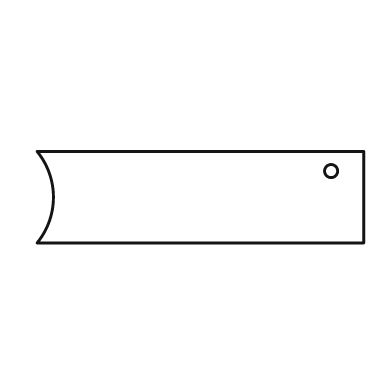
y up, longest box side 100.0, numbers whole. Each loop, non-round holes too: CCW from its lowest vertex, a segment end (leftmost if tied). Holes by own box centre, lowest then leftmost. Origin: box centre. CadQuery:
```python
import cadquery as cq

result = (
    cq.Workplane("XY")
    .moveTo(-50.0, -14.0)
    .lineTo(50.0, -14.0)
    .lineTo(50.0, 14.0)
    .lineTo(-50.0, 14.0)
    .threePointArc((-45.0, 0.0), (-50.0, -14.0))
    .close()
    .moveTo(40.0, 8.0)
    .circle(2.0)
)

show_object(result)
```